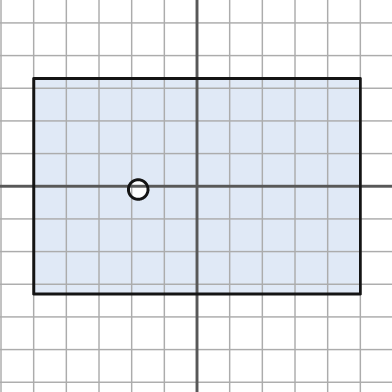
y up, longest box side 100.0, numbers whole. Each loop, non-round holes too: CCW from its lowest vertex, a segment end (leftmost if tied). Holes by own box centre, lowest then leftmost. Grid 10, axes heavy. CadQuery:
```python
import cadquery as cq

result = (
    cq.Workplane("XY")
    .moveTo(-50.0, -33.0)
    .lineTo(50.0, -33.0)
    .lineTo(50.0, 33.0)
    .lineTo(-50.0, 33.0)
    .close()
    .moveTo(-18.0, -1.0)
    .circle(3.0)
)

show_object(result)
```